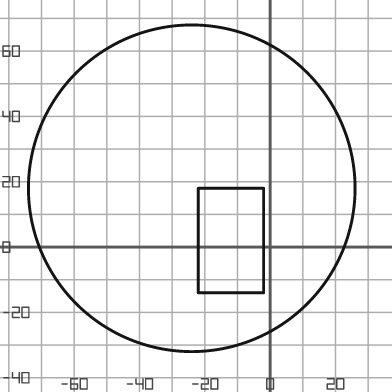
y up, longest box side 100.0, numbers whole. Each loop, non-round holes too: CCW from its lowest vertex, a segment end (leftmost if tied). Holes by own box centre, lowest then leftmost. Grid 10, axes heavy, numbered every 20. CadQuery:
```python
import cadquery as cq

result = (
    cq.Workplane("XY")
    .moveTo(-24.0, 18.0)
    .circle(50.0)
    .moveTo(-22.0, -14.0)
    .lineTo(-2.0, -14.0)
    .lineTo(-2.0, 18.0)
    .lineTo(-22.0, 18.0)
    .close()
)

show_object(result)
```